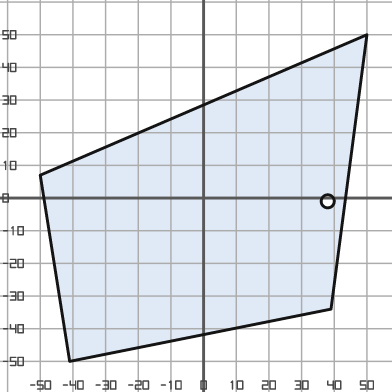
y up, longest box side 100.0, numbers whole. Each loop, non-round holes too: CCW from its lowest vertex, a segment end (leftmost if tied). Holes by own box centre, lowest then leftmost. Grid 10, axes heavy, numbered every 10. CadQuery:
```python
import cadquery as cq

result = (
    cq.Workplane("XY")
    .moveTo(-41.0, -50.0)
    .lineTo(39.0, -34.0)
    .lineTo(50.0, 50.0)
    .lineTo(-50.0, 7.0)
    .close()
    .moveTo(38.0, -1.0)
    .circle(2.0)
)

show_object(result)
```